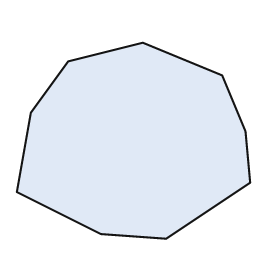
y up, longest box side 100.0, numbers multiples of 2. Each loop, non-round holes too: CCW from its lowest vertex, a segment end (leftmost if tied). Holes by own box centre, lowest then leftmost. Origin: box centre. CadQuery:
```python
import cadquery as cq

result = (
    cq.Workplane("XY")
    .moveTo(14.0, -42.0)
    .lineTo(50.0, -18.0)
    .lineTo(48.0, 4.0)
    .lineTo(38.0, 28.0)
    .lineTo(4.0, 42.0)
    .lineTo(-28.0, 34.0)
    .lineTo(-44.0, 12.0)
    .lineTo(-50.0, -22.0)
    .lineTo(-14.0, -40.0)
    .close()
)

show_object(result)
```